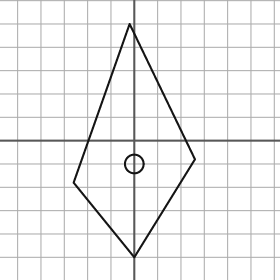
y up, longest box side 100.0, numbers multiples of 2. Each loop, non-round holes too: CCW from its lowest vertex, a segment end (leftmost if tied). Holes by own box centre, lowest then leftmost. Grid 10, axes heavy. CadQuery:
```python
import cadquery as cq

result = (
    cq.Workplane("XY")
    .moveTo(0.0, -50.0)
    .lineTo(26.0, -8.0)
    .lineTo(-2.0, 50.0)
    .lineTo(-26.0, -18.0)
    .close()
    .moveTo(0.0, -10.0)
    .circle(4.0)
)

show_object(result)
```